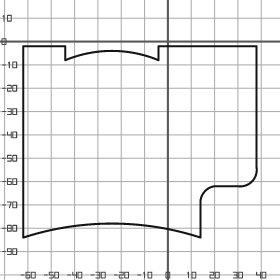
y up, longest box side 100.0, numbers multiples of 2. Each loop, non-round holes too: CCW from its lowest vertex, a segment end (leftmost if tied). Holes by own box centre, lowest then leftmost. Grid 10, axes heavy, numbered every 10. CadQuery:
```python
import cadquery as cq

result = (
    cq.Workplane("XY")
    .moveTo(-62.0, -84.0)
    .threePointArc((-24.0, -78.0), (14.0, -84.0))
    .lineTo(14.0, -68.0)
    .threePointArc((16.0, -64.0), (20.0, -62.0))
    .lineTo(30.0, -62.0)
    .threePointArc((36.0, -60.0), (38.0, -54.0))
    .lineTo(38.0, -2.0)
    .lineTo(-4.0, -2.0)
    .lineTo(-4.0, -8.0)
    .threePointArc((-24.0, -4.0), (-44.0, -8.0))
    .lineTo(-44.0, -2.0)
    .lineTo(-62.0, -2.0)
    .close()
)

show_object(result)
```